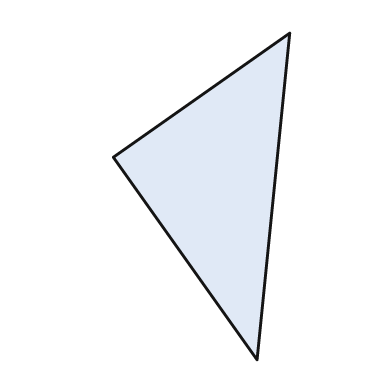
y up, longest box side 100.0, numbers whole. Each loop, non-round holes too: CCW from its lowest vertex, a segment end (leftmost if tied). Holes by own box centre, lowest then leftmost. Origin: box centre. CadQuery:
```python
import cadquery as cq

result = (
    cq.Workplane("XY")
    .moveTo(17.0, -50.0)
    .lineTo(27.0, 50.0)
    .lineTo(-27.0, 12.0)
    .close()
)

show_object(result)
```